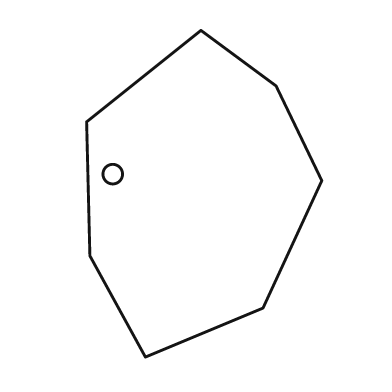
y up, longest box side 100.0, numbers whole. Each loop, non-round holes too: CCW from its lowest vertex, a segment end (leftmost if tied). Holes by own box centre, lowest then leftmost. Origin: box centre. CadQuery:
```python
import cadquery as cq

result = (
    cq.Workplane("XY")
    .moveTo(-18.0, -50.0)
    .lineTo(18.0, -35.0)
    .lineTo(36.0, 4.0)
    .lineTo(22.0, 33.0)
    .lineTo(-1.0, 50.0)
    .lineTo(-36.0, 22.0)
    .lineTo(-35.0, -19.0)
    .close()
    .moveTo(-28.0, 6.0)
    .circle(3.0)
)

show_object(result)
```